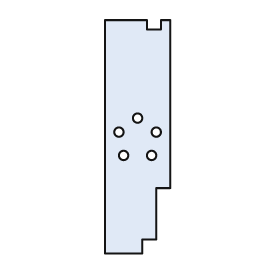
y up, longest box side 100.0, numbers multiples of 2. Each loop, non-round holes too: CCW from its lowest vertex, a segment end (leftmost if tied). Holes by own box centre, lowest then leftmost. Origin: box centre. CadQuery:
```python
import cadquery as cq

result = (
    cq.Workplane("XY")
    .moveTo(-14.0, -50.0)
    .lineTo(2.0, -50.0)
    .lineTo(2.0, -44.0)
    .lineTo(8.0, -44.0)
    .lineTo(8.0, -22.0)
    .lineTo(14.0, -22.0)
    .lineTo(14.0, 50.0)
    .lineTo(10.0, 50.0)
    .lineTo(10.0, 46.0)
    .lineTo(4.0, 46.0)
    .lineTo(4.0, 50.0)
    .lineTo(-14.0, 50.0)
    .close()
    .moveTo(-6.0, -8.0)
    .circle(2.0)
    .moveTo(6.0, -8.0)
    .circle(2.0)
    .moveTo(-8.0, 2.0)
    .circle(2.0)
    .moveTo(8.0, 2.0)
    .circle(2.0)
    .moveTo(0.0, 8.0)
    .circle(2.0)
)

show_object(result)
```